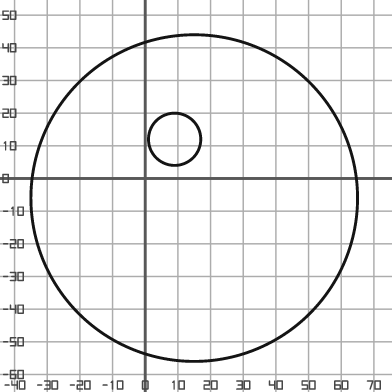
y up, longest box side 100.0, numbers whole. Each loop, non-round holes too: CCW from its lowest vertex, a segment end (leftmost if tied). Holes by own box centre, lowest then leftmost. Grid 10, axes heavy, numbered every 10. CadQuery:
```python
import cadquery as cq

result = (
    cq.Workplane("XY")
    .moveTo(15.0, -6.0)
    .circle(50.0)
    .moveTo(9.0, 12.0)
    .circle(8.0)
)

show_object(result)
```